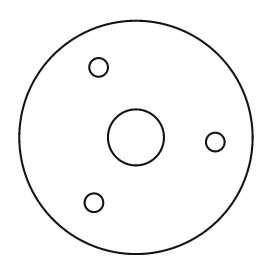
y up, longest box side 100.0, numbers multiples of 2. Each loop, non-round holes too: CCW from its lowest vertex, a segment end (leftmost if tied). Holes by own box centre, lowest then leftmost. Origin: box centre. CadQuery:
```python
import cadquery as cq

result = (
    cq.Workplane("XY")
    .moveTo(0.0, 0.0)
    .circle(50.0)
    .moveTo(-18.0, -28.0)
    .circle(4.0)
    .moveTo(34.0, -2.0)
    .circle(4.0)
    .moveTo(0.0, 0.0)
    .circle(12.0)
    .moveTo(-16.0, 30.0)
    .circle(4.0)
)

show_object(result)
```